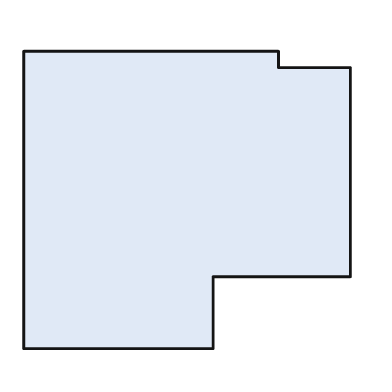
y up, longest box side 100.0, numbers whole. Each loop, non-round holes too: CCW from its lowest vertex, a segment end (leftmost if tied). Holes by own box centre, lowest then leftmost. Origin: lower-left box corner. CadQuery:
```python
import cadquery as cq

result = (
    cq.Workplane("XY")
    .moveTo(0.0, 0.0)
    .lineTo(58.0, 0.0)
    .lineTo(58.0, 22.0)
    .lineTo(100.0, 22.0)
    .lineTo(100.0, 86.0)
    .lineTo(78.0, 86.0)
    .lineTo(78.0, 91.0)
    .lineTo(0.0, 91.0)
    .close()
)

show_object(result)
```